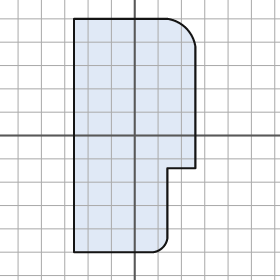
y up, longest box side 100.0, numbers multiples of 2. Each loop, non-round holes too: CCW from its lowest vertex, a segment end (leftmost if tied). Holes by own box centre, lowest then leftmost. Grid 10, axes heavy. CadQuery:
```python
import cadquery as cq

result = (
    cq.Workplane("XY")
    .moveTo(-26.0, -50.0)
    .lineTo(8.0, -50.0)
    .threePointArc((12.0, -48.0), (14.0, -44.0))
    .lineTo(14.0, -14.0)
    .lineTo(26.0, -14.0)
    .lineTo(26.0, 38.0)
    .threePointArc((22.0, 46.0), (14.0, 50.0))
    .lineTo(-26.0, 50.0)
    .close()
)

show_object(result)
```